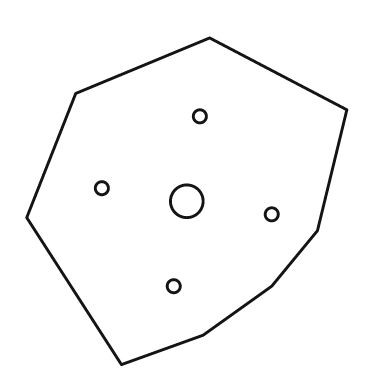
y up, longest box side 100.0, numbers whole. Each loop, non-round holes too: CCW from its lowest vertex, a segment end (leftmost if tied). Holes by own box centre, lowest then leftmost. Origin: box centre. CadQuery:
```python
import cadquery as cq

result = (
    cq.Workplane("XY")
    .moveTo(-20.0, -50.0)
    .lineTo(5.0, -41.0)
    .lineTo(26.0, -26.0)
    .lineTo(40.0, -9.0)
    .lineTo(49.0, 28.0)
    .lineTo(7.0, 50.0)
    .lineTo(-34.0, 33.0)
    .lineTo(-49.0, -5.0)
    .close()
    .moveTo(-4.0, -26.0)
    .circle(2.0)
    .moveTo(26.0, -4.0)
    .circle(2.0)
    .moveTo(0.0, 0.0)
    .circle(5.0)
    .moveTo(-26.0, 4.0)
    .circle(2.0)
    .moveTo(4.0, 26.0)
    .circle(2.0)
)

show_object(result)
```